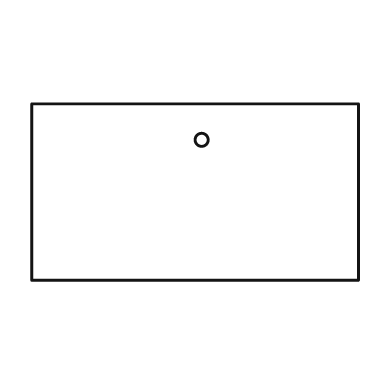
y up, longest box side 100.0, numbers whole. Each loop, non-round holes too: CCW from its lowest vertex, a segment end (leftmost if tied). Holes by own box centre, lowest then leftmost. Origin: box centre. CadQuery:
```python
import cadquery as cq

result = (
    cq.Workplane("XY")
    .moveTo(-50.0, -27.0)
    .lineTo(50.0, -27.0)
    .lineTo(50.0, 27.0)
    .lineTo(-50.0, 27.0)
    .close()
    .moveTo(2.0, 16.0)
    .circle(2.0)
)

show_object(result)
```